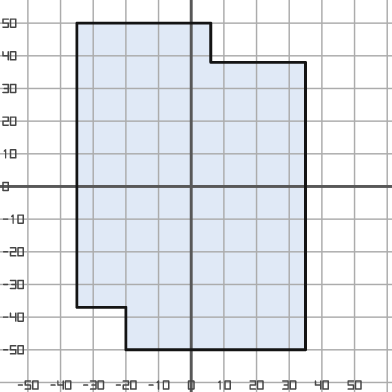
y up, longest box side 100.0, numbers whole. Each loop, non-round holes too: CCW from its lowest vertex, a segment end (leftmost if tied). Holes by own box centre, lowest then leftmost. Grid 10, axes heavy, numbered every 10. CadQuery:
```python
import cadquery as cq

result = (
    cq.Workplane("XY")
    .moveTo(-20.0, -50.0)
    .lineTo(35.0, -50.0)
    .lineTo(35.0, 38.0)
    .lineTo(6.0, 38.0)
    .lineTo(6.0, 50.0)
    .lineTo(-35.0, 50.0)
    .lineTo(-35.0, -37.0)
    .lineTo(-20.0, -37.0)
    .close()
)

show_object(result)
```